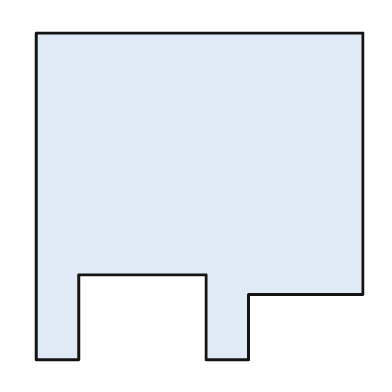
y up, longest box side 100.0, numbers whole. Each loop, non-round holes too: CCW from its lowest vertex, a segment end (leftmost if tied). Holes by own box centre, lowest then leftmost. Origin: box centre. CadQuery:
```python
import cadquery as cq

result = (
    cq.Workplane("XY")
    .moveTo(-50.0, -50.0)
    .lineTo(-37.0, -50.0)
    .lineTo(-37.0, -24.0)
    .lineTo(2.0, -24.0)
    .lineTo(2.0, -50.0)
    .lineTo(15.0, -50.0)
    .lineTo(15.0, -30.0)
    .lineTo(50.0, -30.0)
    .lineTo(50.0, 50.0)
    .lineTo(-50.0, 50.0)
    .close()
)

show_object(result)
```